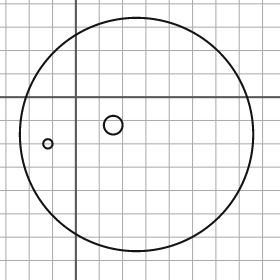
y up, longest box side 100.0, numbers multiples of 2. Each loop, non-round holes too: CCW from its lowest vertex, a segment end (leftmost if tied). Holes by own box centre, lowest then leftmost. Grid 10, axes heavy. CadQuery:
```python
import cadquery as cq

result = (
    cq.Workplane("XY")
    .moveTo(26.0, -16.0)
    .circle(50.0)
    .moveTo(-12.0, -20.0)
    .circle(2.0)
    .moveTo(16.0, -12.0)
    .circle(4.0)
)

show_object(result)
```